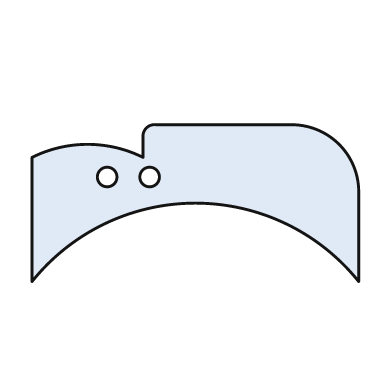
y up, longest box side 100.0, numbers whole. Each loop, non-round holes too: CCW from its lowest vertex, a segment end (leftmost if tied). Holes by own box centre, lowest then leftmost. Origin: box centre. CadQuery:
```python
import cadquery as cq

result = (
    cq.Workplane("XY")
    .moveTo(-50.0, -24.0)
    .threePointArc((0.0, 0.0), (50.0, -24.0))
    .lineTo(50.0, 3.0)
    .threePointArc((44.0, 18.0), (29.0, 24.0))
    .lineTo(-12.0, 24.0)
    .threePointArc((-15.0, 23.0), (-16.0, 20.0))
    .lineTo(-16.0, 14.0)
    .threePointArc((-33.0, 18.0), (-50.0, 14.0))
    .close()
    .moveTo(-27.0, 8.0)
    .circle(3.0)
    .moveTo(-14.0, 8.0)
    .circle(3.0)
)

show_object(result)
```